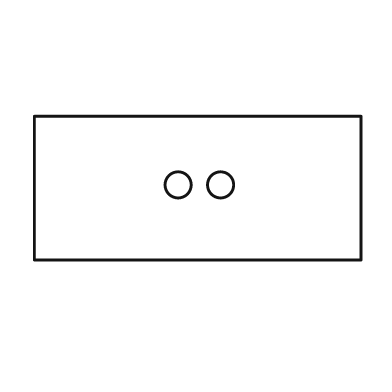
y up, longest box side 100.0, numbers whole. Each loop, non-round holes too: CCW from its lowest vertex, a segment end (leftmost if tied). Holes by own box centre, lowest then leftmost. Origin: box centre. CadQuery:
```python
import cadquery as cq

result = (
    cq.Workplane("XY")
    .moveTo(-50.0, -22.0)
    .lineTo(50.0, -22.0)
    .lineTo(50.0, 22.0)
    .lineTo(-50.0, 22.0)
    .close()
    .moveTo(-6.0, 1.0)
    .circle(4.0)
    .moveTo(7.0, 1.0)
    .circle(4.0)
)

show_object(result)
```